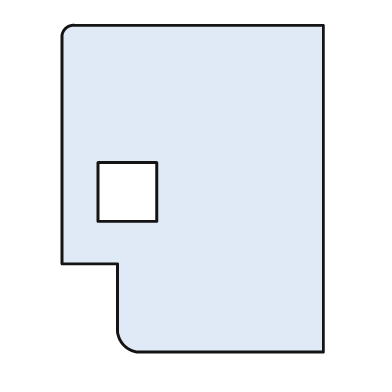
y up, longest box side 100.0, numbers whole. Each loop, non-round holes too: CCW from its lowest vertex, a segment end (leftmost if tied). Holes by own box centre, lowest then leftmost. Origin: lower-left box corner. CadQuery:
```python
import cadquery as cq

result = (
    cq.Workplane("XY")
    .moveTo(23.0, 0.0)
    .lineTo(80.0, 0.0)
    .lineTo(80.0, 100.0)
    .lineTo(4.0, 100.0)
    .threePointArc((1.0, 99.0), (0.0, 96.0))
    .lineTo(0.0, 27.0)
    .lineTo(17.0, 27.0)
    .lineTo(17.0, 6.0)
    .threePointArc((19.0, 2.0), (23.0, 0.0))
    .close()
    .moveTo(11.0, 40.0)
    .lineTo(29.0, 40.0)
    .lineTo(29.0, 58.0)
    .lineTo(11.0, 58.0)
    .close()
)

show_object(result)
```